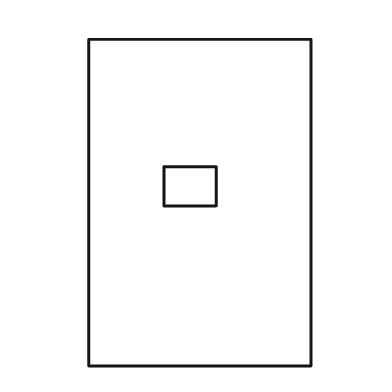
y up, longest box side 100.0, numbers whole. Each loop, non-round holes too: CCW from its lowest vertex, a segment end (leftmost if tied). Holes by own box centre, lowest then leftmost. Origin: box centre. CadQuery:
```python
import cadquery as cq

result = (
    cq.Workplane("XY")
    .moveTo(-34.0, -50.0)
    .lineTo(34.0, -50.0)
    .lineTo(34.0, 50.0)
    .lineTo(-34.0, 50.0)
    .close()
    .moveTo(-11.0, -1.0)
    .lineTo(5.0, -1.0)
    .lineTo(5.0, 11.0)
    .lineTo(-11.0, 11.0)
    .close()
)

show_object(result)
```